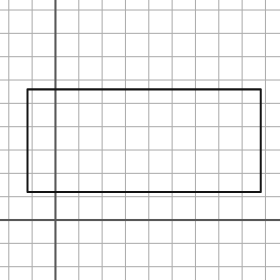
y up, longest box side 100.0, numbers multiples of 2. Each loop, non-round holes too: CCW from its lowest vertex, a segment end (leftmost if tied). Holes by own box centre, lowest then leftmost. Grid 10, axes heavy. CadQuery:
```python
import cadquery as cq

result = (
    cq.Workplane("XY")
    .moveTo(-12.0, 12.0)
    .lineTo(88.0, 12.0)
    .lineTo(88.0, 56.0)
    .lineTo(-12.0, 56.0)
    .close()
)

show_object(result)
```